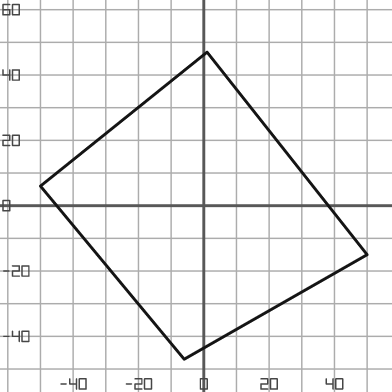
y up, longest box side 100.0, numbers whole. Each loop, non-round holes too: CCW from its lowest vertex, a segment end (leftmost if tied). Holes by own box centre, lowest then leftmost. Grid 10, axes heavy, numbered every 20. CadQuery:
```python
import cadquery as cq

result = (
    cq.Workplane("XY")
    .moveTo(-6.0, -47.0)
    .lineTo(50.0, -15.0)
    .lineTo(1.0, 47.0)
    .lineTo(-50.0, 6.0)
    .close()
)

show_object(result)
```